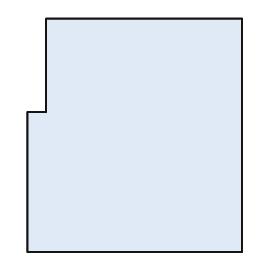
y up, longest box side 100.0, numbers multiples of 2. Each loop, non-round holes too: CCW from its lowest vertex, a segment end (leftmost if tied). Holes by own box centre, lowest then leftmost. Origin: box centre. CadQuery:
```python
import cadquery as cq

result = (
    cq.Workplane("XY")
    .moveTo(-46.0, -50.0)
    .lineTo(46.0, -50.0)
    .lineTo(46.0, 50.0)
    .lineTo(-38.0, 50.0)
    .lineTo(-38.0, 10.0)
    .lineTo(-46.0, 10.0)
    .close()
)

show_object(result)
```